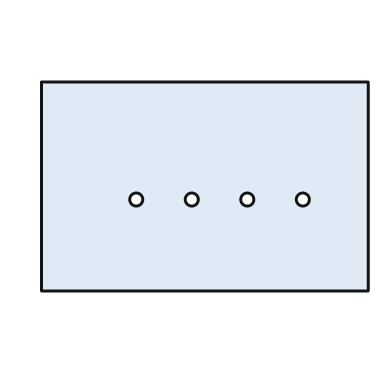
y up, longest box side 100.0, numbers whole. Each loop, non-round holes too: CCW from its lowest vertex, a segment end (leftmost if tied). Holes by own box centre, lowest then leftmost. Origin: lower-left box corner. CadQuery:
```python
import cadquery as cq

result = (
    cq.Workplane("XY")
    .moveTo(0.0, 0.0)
    .lineTo(100.0, 0.0)
    .lineTo(100.0, 64.0)
    .lineTo(0.0, 64.0)
    .close()
    .moveTo(29.0, 28.0)
    .circle(2.0)
    .moveTo(46.0, 28.0)
    .circle(2.0)
    .moveTo(63.0, 28.0)
    .circle(2.0)
    .moveTo(80.0, 28.0)
    .circle(2.0)
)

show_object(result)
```